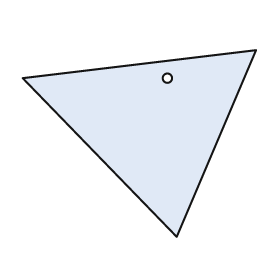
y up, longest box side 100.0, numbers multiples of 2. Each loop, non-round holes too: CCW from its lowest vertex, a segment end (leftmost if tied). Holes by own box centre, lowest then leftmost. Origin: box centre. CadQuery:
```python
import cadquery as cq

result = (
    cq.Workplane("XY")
    .moveTo(16.0, -40.0)
    .lineTo(50.0, 40.0)
    .lineTo(-50.0, 28.0)
    .close()
    .moveTo(12.0, 28.0)
    .circle(2.0)
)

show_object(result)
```